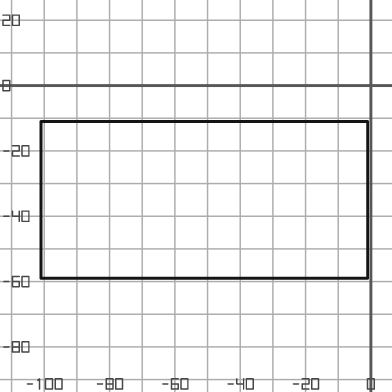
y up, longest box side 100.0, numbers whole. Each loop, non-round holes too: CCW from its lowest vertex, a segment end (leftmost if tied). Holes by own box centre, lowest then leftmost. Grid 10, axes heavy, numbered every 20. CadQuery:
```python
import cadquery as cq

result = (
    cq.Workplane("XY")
    .moveTo(-101.0, -59.0)
    .lineTo(-1.0, -59.0)
    .lineTo(-1.0, -11.0)
    .lineTo(-101.0, -11.0)
    .close()
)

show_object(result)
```